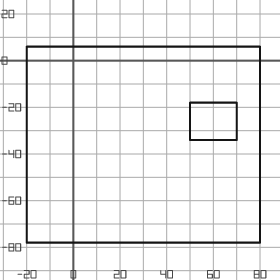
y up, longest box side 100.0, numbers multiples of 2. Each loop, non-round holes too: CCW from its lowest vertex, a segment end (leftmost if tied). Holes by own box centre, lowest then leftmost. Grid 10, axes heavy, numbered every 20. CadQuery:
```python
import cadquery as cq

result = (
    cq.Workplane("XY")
    .moveTo(-20.0, -78.0)
    .lineTo(80.0, -78.0)
    .lineTo(80.0, 6.0)
    .lineTo(-20.0, 6.0)
    .close()
    .moveTo(50.0, -34.0)
    .lineTo(70.0, -34.0)
    .lineTo(70.0, -18.0)
    .lineTo(50.0, -18.0)
    .close()
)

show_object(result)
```